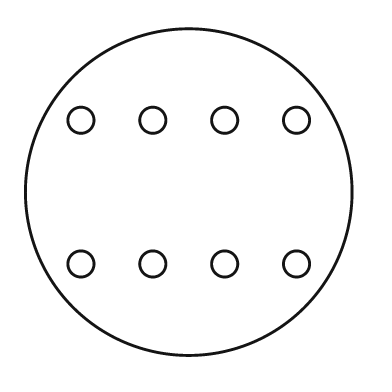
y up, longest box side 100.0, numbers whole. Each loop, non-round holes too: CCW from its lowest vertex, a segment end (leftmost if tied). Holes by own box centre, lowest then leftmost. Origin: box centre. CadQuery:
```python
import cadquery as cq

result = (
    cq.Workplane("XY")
    .moveTo(0.0, 0.0)
    .circle(50.0)
    .moveTo(-33.0, -22.0)
    .circle(4.0)
    .moveTo(-11.0, -22.0)
    .circle(4.0)
    .moveTo(11.0, -22.0)
    .circle(4.0)
    .moveTo(33.0, -22.0)
    .circle(4.0)
    .moveTo(-33.0, 22.0)
    .circle(4.0)
    .moveTo(-11.0, 22.0)
    .circle(4.0)
    .moveTo(11.0, 22.0)
    .circle(4.0)
    .moveTo(33.0, 22.0)
    .circle(4.0)
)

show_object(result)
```